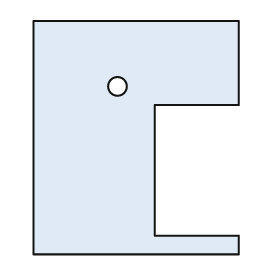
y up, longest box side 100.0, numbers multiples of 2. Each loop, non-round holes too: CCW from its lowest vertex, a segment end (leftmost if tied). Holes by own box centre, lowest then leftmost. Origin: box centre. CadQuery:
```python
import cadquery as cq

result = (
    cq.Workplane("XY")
    .moveTo(-44.0, -50.0)
    .lineTo(44.0, -50.0)
    .lineTo(44.0, -42.0)
    .lineTo(8.0, -42.0)
    .lineTo(8.0, 14.0)
    .lineTo(44.0, 14.0)
    .lineTo(44.0, 50.0)
    .lineTo(-44.0, 50.0)
    .close()
    .moveTo(-8.0, 22.0)
    .circle(4.0)
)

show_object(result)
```